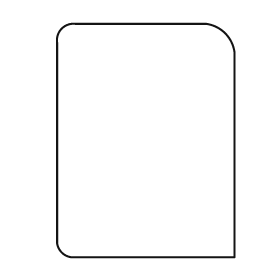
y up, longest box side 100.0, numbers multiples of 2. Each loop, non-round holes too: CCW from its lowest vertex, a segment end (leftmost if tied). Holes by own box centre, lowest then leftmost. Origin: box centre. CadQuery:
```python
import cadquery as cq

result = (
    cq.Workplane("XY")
    .moveTo(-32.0, -50.0)
    .lineTo(38.0, -50.0)
    .lineTo(38.0, 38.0)
    .threePointArc((34.0, 46.0), (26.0, 50.0))
    .lineTo(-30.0, 50.0)
    .threePointArc((-36.0, 48.0), (-38.0, 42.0))
    .lineTo(-38.0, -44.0)
    .threePointArc((-36.0, -48.0), (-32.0, -50.0))
    .close()
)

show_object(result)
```